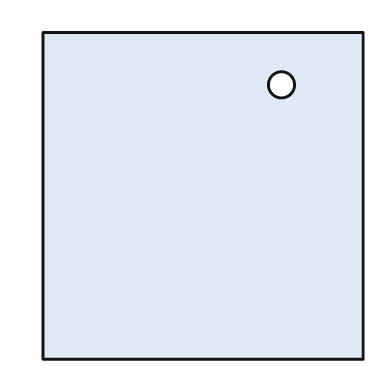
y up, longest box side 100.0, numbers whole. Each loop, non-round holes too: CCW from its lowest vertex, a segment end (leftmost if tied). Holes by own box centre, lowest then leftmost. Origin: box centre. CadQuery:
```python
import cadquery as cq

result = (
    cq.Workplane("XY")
    .moveTo(-49.0, -50.0)
    .lineTo(49.0, -50.0)
    .lineTo(49.0, 50.0)
    .lineTo(-49.0, 50.0)
    .close()
    .moveTo(24.0, 34.0)
    .circle(4.0)
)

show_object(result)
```